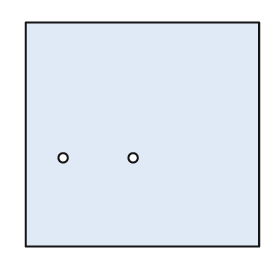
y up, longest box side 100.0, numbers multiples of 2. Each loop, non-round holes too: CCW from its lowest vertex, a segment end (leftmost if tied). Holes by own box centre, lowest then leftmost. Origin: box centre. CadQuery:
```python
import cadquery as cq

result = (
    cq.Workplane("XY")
    .moveTo(-50.0, -48.0)
    .lineTo(50.0, -48.0)
    .lineTo(50.0, 48.0)
    .lineTo(-50.0, 48.0)
    .close()
    .moveTo(-34.0, -10.0)
    .circle(2.0)
    .moveTo(-4.0, -10.0)
    .circle(2.0)
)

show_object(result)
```